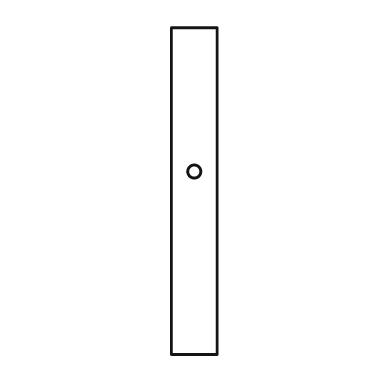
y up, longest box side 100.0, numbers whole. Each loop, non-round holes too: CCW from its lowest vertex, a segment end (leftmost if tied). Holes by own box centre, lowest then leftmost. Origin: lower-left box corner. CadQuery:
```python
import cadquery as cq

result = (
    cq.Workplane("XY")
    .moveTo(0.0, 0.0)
    .lineTo(14.0, 0.0)
    .lineTo(14.0, 100.0)
    .lineTo(0.0, 100.0)
    .close()
    .moveTo(7.0, 56.0)
    .circle(2.0)
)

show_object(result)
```